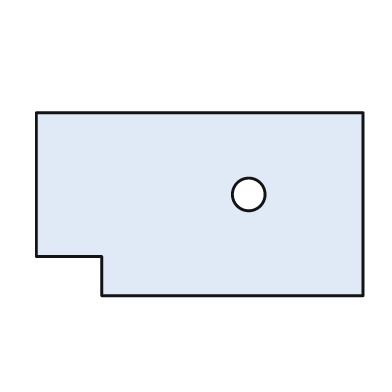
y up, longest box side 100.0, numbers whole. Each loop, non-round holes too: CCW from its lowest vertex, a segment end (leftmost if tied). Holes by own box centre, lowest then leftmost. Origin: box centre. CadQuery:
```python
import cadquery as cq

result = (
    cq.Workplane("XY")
    .moveTo(-30.0, -28.0)
    .lineTo(50.0, -28.0)
    .lineTo(50.0, 28.0)
    .lineTo(-50.0, 28.0)
    .lineTo(-50.0, -16.0)
    .lineTo(-30.0, -16.0)
    .close()
    .moveTo(15.0, 3.0)
    .circle(5.0)
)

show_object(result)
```